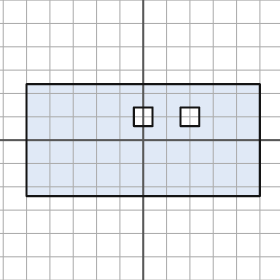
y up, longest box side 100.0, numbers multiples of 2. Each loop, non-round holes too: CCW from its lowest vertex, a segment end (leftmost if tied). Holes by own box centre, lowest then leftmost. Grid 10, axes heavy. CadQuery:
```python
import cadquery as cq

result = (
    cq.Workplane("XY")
    .moveTo(-50.0, -24.0)
    .lineTo(50.0, -24.0)
    .lineTo(50.0, 24.0)
    .lineTo(-50.0, 24.0)
    .close()
    .moveTo(-4.0, 6.0)
    .lineTo(4.0, 6.0)
    .lineTo(4.0, 14.0)
    .lineTo(-4.0, 14.0)
    .close()
    .moveTo(16.0, 6.0)
    .lineTo(24.0, 6.0)
    .lineTo(24.0, 14.0)
    .lineTo(16.0, 14.0)
    .close()
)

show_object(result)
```